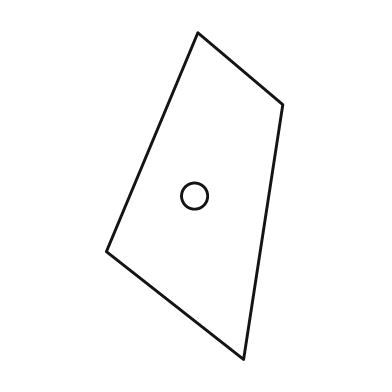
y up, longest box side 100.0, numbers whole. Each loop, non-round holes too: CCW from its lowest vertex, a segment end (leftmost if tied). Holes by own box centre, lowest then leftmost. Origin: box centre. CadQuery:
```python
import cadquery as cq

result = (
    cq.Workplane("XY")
    .moveTo(15.0, -50.0)
    .lineTo(27.0, 28.0)
    .lineTo(1.0, 50.0)
    .lineTo(-27.0, -17.0)
    .close()
    .moveTo(0.0, 0.0)
    .circle(4.0)
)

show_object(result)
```